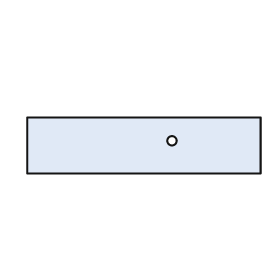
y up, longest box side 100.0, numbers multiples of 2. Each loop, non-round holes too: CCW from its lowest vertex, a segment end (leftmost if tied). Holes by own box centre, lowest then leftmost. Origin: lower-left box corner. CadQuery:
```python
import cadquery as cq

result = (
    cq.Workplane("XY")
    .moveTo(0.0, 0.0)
    .lineTo(100.0, 0.0)
    .lineTo(100.0, 24.0)
    .lineTo(0.0, 24.0)
    .close()
    .moveTo(62.0, 14.0)
    .circle(2.0)
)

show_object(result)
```